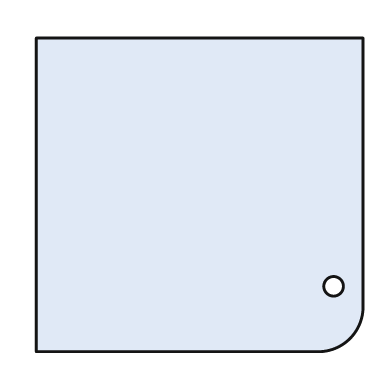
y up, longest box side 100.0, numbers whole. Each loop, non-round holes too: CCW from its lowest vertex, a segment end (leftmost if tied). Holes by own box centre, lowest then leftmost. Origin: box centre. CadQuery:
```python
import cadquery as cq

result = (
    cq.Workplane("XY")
    .moveTo(-50.0, -48.0)
    .lineTo(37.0, -48.0)
    .threePointArc((46.0, -44.0), (50.0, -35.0))
    .lineTo(50.0, 48.0)
    .lineTo(-50.0, 48.0)
    .close()
    .moveTo(41.0, -28.0)
    .circle(3.0)
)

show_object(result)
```